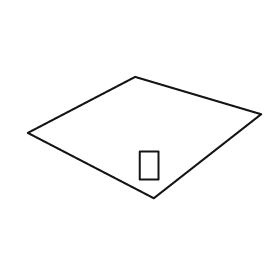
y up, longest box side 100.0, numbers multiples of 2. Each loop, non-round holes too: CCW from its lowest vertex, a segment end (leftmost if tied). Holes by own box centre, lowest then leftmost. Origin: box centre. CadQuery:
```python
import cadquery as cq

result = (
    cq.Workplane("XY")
    .moveTo(4.0, -26.0)
    .lineTo(50.0, 10.0)
    .lineTo(-4.0, 26.0)
    .lineTo(-50.0, 2.0)
    .close()
    .moveTo(-2.0, -18.0)
    .lineTo(6.0, -18.0)
    .lineTo(6.0, -6.0)
    .lineTo(-2.0, -6.0)
    .close()
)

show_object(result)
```